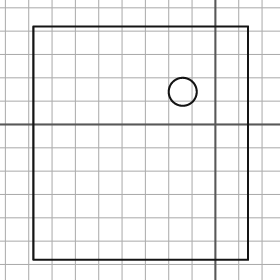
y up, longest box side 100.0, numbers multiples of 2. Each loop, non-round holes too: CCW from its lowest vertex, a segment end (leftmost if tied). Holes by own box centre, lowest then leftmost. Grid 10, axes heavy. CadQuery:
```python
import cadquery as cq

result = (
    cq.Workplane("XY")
    .moveTo(-78.0, -58.0)
    .lineTo(14.0, -58.0)
    .lineTo(14.0, 42.0)
    .lineTo(-78.0, 42.0)
    .close()
    .moveTo(-14.0, 14.0)
    .circle(6.0)
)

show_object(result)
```